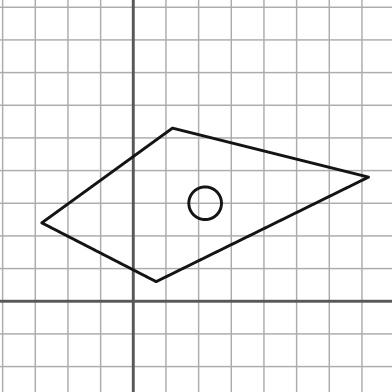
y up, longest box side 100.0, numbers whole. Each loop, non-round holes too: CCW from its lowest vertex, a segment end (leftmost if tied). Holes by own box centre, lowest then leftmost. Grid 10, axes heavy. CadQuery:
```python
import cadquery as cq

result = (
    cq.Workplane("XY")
    .moveTo(7.0, 6.0)
    .lineTo(72.0, 38.0)
    .lineTo(12.0, 53.0)
    .lineTo(-28.0, 24.0)
    .close()
    .moveTo(22.0, 30.0)
    .circle(5.0)
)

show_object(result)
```